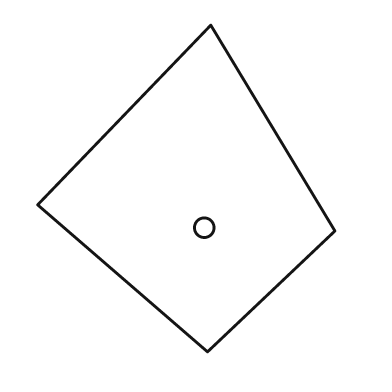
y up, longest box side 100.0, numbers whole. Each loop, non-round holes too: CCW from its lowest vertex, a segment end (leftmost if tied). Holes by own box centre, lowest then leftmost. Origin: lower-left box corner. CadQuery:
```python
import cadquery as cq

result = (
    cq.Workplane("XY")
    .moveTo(52.0, 0.0)
    .lineTo(91.0, 37.0)
    .lineTo(53.0, 100.0)
    .lineTo(0.0, 45.0)
    .close()
    .moveTo(51.0, 38.0)
    .circle(3.0)
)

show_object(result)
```